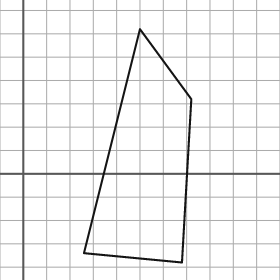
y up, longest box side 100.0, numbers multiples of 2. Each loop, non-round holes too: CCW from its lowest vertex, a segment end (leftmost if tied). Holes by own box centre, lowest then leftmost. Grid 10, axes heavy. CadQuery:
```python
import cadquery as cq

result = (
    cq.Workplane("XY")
    .moveTo(68.0, -38.0)
    .lineTo(72.0, 32.0)
    .lineTo(50.0, 62.0)
    .lineTo(26.0, -34.0)
    .close()
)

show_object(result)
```